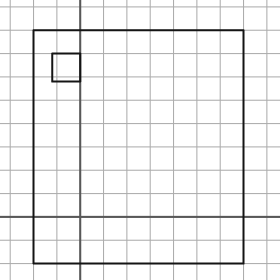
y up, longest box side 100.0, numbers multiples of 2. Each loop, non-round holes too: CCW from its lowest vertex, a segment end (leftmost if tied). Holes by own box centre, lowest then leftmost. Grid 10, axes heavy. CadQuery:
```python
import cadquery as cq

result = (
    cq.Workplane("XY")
    .moveTo(-20.0, -20.0)
    .lineTo(70.0, -20.0)
    .lineTo(70.0, 80.0)
    .lineTo(-20.0, 80.0)
    .close()
    .moveTo(-12.0, 58.0)
    .lineTo(0.0, 58.0)
    .lineTo(0.0, 70.0)
    .lineTo(-12.0, 70.0)
    .close()
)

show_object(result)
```